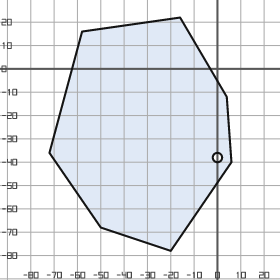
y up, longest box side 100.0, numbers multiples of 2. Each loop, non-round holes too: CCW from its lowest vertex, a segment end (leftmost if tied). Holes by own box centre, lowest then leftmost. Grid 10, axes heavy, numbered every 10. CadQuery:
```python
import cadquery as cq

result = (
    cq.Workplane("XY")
    .moveTo(-20.0, -78.0)
    .lineTo(6.0, -40.0)
    .lineTo(4.0, -12.0)
    .lineTo(-16.0, 22.0)
    .lineTo(-58.0, 16.0)
    .lineTo(-72.0, -36.0)
    .lineTo(-50.0, -68.0)
    .close()
    .moveTo(0.0, -38.0)
    .circle(2.0)
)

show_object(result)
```